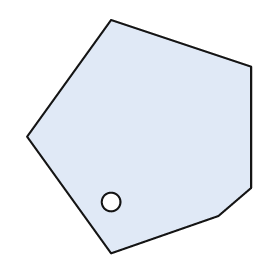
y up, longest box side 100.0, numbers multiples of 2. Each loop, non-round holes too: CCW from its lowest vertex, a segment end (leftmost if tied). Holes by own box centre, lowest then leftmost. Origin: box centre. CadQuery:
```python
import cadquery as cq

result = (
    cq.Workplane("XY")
    .moveTo(-12.0, -50.0)
    .lineTo(34.0, -34.0)
    .lineTo(48.0, -22.0)
    .lineTo(48.0, 30.0)
    .lineTo(-12.0, 50.0)
    .lineTo(-48.0, 0.0)
    .close()
    .moveTo(-12.0, -28.0)
    .circle(4.0)
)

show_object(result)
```